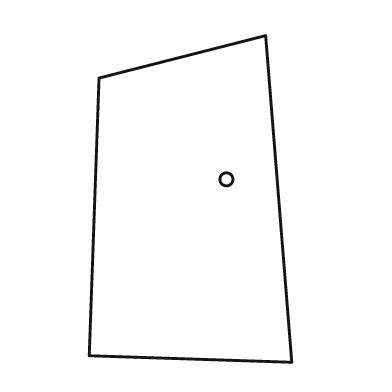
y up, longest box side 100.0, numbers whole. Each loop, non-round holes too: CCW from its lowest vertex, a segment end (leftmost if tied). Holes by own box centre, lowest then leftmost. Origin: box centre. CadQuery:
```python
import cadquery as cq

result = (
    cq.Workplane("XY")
    .moveTo(31.0, -50.0)
    .lineTo(23.0, 50.0)
    .lineTo(-28.0, 37.0)
    .lineTo(-31.0, -48.0)
    .close()
    .moveTo(11.0, 6.0)
    .circle(2.0)
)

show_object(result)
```